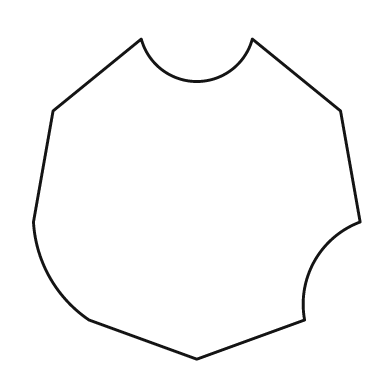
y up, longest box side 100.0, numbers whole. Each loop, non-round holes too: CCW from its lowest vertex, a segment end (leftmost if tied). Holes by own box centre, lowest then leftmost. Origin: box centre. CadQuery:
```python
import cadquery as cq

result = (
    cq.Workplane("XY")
    .moveTo(0.0, -49.0)
    .lineTo(33.0, -37.0)
    .threePointArc((36.0, -19.0), (50.0, -7.0))
    .lineTo(44.0, 27.0)
    .lineTo(17.0, 49.0)
    .threePointArc((0.0, 36.0), (-17.0, 49.0))
    .lineTo(-44.0, 27.0)
    .lineTo(-50.0, -7.0)
    .threePointArc((-45.0, -24.0), (-33.0, -37.0))
    .close()
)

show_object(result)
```